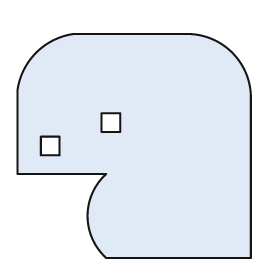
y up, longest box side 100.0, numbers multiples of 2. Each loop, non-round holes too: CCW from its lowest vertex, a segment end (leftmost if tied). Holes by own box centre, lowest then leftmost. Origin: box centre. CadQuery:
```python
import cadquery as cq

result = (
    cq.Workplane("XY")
    .moveTo(-12.0, -48.0)
    .lineTo(50.0, -48.0)
    .lineTo(50.0, 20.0)
    .threePointArc((42.0, 40.0), (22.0, 48.0))
    .lineTo(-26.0, 48.0)
    .threePointArc((-42.0, 40.0), (-50.0, 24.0))
    .lineTo(-50.0, -12.0)
    .lineTo(-12.0, -12.0)
    .threePointArc((-20.0, -30.0), (-12.0, -48.0))
    .close()
    .moveTo(-40.0, -4.0)
    .lineTo(-32.0, -4.0)
    .lineTo(-32.0, 4.0)
    .lineTo(-40.0, 4.0)
    .close()
    .moveTo(-14.0, 6.0)
    .lineTo(-6.0, 6.0)
    .lineTo(-6.0, 14.0)
    .lineTo(-14.0, 14.0)
    .close()
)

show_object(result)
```